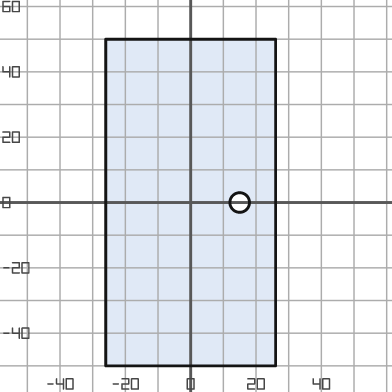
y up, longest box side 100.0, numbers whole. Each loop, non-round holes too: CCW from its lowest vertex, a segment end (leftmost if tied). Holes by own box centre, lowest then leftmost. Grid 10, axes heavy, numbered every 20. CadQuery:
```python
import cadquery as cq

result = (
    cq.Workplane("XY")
    .moveTo(-26.0, -50.0)
    .lineTo(26.0, -50.0)
    .lineTo(26.0, 50.0)
    .lineTo(-26.0, 50.0)
    .close()
    .moveTo(15.0, 0.0)
    .circle(3.0)
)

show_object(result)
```